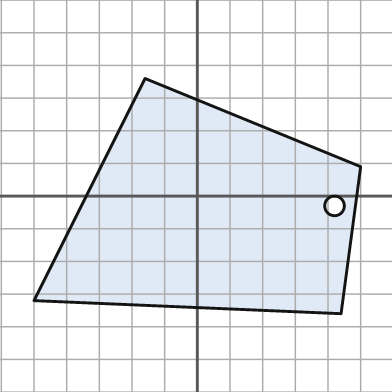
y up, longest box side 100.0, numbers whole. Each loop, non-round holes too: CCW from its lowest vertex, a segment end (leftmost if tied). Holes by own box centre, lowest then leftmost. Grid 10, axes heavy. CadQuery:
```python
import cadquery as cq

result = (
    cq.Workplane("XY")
    .moveTo(44.0, -36.0)
    .lineTo(50.0, 9.0)
    .lineTo(-16.0, 36.0)
    .lineTo(-50.0, -32.0)
    .close()
    .moveTo(42.0, -3.0)
    .circle(3.0)
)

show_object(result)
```